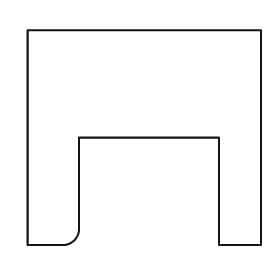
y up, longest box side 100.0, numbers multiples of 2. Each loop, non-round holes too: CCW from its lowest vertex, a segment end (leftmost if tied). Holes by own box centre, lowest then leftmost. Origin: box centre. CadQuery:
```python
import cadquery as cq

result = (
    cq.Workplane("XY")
    .moveTo(-50.0, -46.0)
    .lineTo(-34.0, -46.0)
    .threePointArc((-30.0, -44.0), (-28.0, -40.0))
    .lineTo(-28.0, 0.0)
    .lineTo(32.0, 0.0)
    .lineTo(32.0, -46.0)
    .lineTo(50.0, -46.0)
    .lineTo(50.0, 46.0)
    .lineTo(-50.0, 46.0)
    .close()
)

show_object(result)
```